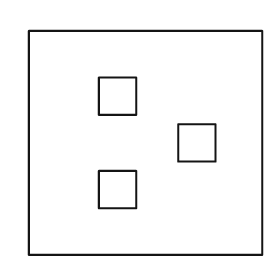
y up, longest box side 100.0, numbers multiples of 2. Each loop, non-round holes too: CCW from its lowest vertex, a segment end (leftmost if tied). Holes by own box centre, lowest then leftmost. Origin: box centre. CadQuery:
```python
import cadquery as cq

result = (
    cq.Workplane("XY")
    .moveTo(-50.0, -48.0)
    .lineTo(50.0, -48.0)
    .lineTo(50.0, 48.0)
    .lineTo(-50.0, 48.0)
    .close()
    .moveTo(-20.0, -28.0)
    .lineTo(-4.0, -28.0)
    .lineTo(-4.0, -12.0)
    .lineTo(-20.0, -12.0)
    .close()
    .moveTo(14.0, -8.0)
    .lineTo(30.0, -8.0)
    .lineTo(30.0, 8.0)
    .lineTo(14.0, 8.0)
    .close()
    .moveTo(-20.0, 12.0)
    .lineTo(-4.0, 12.0)
    .lineTo(-4.0, 28.0)
    .lineTo(-20.0, 28.0)
    .close()
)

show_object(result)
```